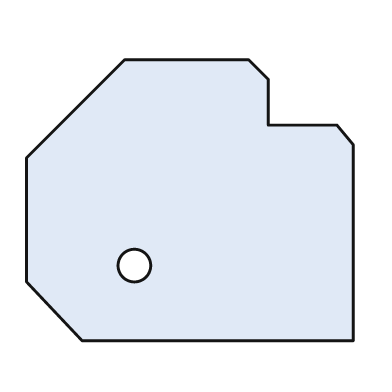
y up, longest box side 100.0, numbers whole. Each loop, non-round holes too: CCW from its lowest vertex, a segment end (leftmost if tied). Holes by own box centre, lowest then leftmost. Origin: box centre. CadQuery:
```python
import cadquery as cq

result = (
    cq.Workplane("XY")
    .moveTo(-33.0, -43.0)
    .lineTo(50.0, -43.0)
    .lineTo(50.0, 17.0)
    .lineTo(45.0, 23.0)
    .lineTo(24.0, 23.0)
    .lineTo(24.0, 37.0)
    .lineTo(18.0, 43.0)
    .lineTo(-20.0, 43.0)
    .lineTo(-50.0, 13.0)
    .lineTo(-50.0, -25.0)
    .close()
    .moveTo(-17.0, -20.0)
    .circle(5.0)
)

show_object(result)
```